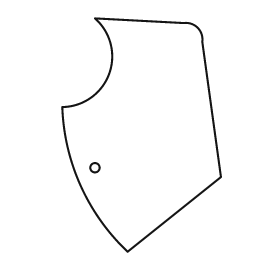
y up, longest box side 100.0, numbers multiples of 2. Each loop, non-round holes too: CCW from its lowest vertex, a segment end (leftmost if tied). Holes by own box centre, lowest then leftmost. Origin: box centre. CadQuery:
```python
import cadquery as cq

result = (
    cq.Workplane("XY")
    .moveTo(-6.0, -50.0)
    .lineTo(34.0, -18.0)
    .lineTo(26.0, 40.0)
    .threePointArc((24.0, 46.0), (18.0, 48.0))
    .lineTo(-20.0, 50.0)
    .threePointArc((-14.0, 26.0), (-34.0, 12.0))
    .threePointArc((-26.0, -22.0), (-6.0, -50.0))
    .close()
    .moveTo(-20.0, -14.0)
    .circle(2.0)
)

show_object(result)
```